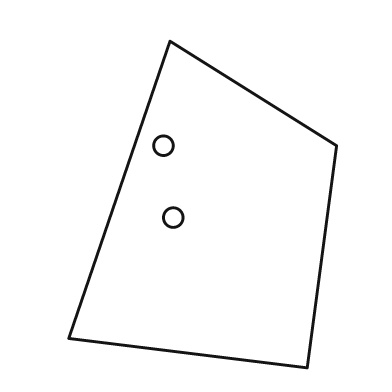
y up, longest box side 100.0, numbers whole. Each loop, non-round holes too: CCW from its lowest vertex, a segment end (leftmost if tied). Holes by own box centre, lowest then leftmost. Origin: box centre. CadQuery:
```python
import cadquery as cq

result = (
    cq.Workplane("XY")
    .moveTo(32.0, -50.0)
    .lineTo(41.0, 18.0)
    .lineTo(-10.0, 50.0)
    .lineTo(-41.0, -41.0)
    .close()
    .moveTo(-9.0, -4.0)
    .circle(3.0)
    .moveTo(-12.0, 18.0)
    .circle(3.0)
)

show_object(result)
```